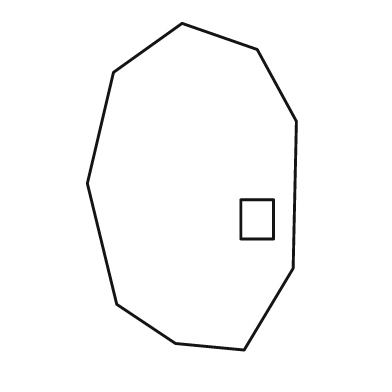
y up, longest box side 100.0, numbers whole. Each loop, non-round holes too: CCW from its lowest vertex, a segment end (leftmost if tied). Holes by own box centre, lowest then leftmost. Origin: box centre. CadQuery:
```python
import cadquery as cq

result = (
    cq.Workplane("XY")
    .moveTo(16.0, -50.0)
    .lineTo(31.0, -25.0)
    .lineTo(32.0, 20.0)
    .lineTo(20.0, 42.0)
    .lineTo(-3.0, 50.0)
    .lineTo(-24.0, 35.0)
    .lineTo(-32.0, 1.0)
    .lineTo(-23.0, -36.0)
    .lineTo(-5.0, -48.0)
    .close()
    .moveTo(15.0, -16.0)
    .lineTo(25.0, -16.0)
    .lineTo(25.0, -4.0)
    .lineTo(15.0, -4.0)
    .close()
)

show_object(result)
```